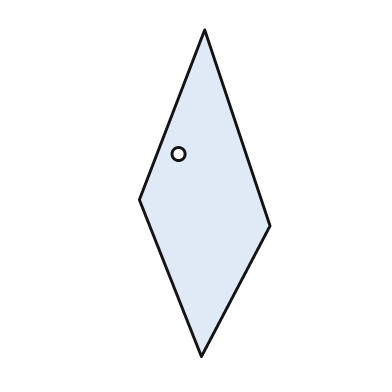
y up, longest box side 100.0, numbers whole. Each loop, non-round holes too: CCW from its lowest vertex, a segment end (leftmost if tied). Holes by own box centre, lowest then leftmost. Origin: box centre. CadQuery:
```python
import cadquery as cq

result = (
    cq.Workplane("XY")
    .moveTo(-1.0, -50.0)
    .lineTo(20.0, -10.0)
    .lineTo(0.0, 50.0)
    .lineTo(-20.0, -2.0)
    .close()
    .moveTo(-8.0, 12.0)
    .circle(2.0)
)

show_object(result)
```